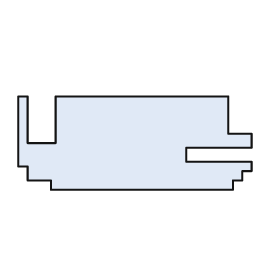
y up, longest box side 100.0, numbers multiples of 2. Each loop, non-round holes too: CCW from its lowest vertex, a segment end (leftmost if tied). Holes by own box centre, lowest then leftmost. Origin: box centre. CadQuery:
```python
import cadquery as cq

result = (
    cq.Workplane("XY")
    .moveTo(-36.0, -20.0)
    .lineTo(42.0, -20.0)
    .lineTo(42.0, -16.0)
    .lineTo(46.0, -16.0)
    .lineTo(46.0, -12.0)
    .lineTo(50.0, -12.0)
    .lineTo(50.0, -8.0)
    .lineTo(22.0, -8.0)
    .lineTo(22.0, -2.0)
    .lineTo(50.0, -2.0)
    .lineTo(50.0, 4.0)
    .lineTo(40.0, 4.0)
    .lineTo(40.0, 20.0)
    .lineTo(-34.0, 20.0)
    .lineTo(-34.0, 0.0)
    .lineTo(-46.0, 0.0)
    .lineTo(-46.0, 20.0)
    .lineTo(-50.0, 20.0)
    .lineTo(-50.0, -10.0)
    .lineTo(-46.0, -10.0)
    .lineTo(-46.0, -16.0)
    .lineTo(-36.0, -16.0)
    .close()
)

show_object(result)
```